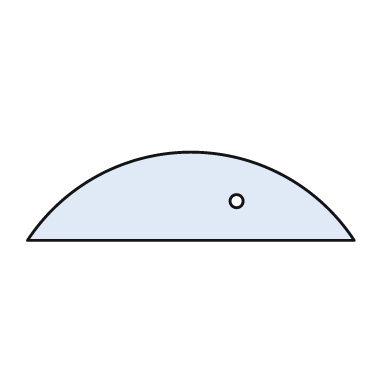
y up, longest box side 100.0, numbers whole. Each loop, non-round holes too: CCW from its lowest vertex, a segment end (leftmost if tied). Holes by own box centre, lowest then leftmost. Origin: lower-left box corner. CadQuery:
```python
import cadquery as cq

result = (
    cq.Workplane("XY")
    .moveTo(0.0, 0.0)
    .lineTo(100.0, 0.0)
    .threePointArc((50.0, 27.0), (0.0, 0.0))
    .close()
    .moveTo(64.0, 12.0)
    .circle(2.0)
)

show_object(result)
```